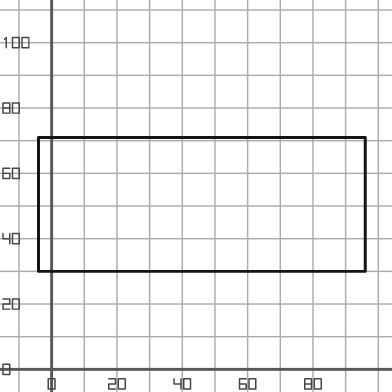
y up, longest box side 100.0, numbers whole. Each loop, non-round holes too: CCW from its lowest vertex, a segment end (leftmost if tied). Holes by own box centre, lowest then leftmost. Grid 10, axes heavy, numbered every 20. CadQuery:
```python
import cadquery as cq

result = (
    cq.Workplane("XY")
    .moveTo(-4.0, 30.0)
    .lineTo(96.0, 30.0)
    .lineTo(96.0, 71.0)
    .lineTo(-4.0, 71.0)
    .close()
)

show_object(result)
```